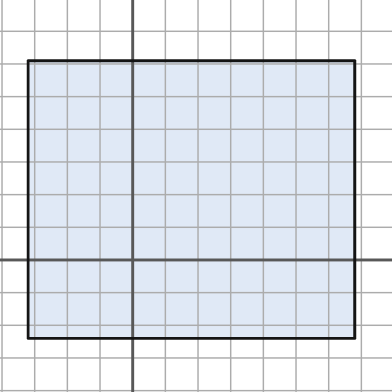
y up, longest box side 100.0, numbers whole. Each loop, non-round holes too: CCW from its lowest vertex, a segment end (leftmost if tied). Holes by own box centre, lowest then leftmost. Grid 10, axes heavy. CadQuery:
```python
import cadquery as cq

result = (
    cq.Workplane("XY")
    .moveTo(-32.0, -24.0)
    .lineTo(68.0, -24.0)
    .lineTo(68.0, 61.0)
    .lineTo(-32.0, 61.0)
    .close()
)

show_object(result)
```